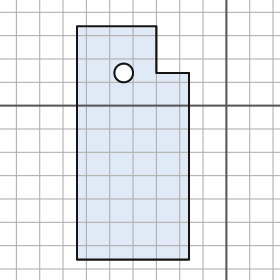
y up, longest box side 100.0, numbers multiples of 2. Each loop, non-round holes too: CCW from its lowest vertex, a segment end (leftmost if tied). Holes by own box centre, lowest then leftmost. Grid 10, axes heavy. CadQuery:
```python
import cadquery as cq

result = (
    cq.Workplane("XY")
    .moveTo(-64.0, -66.0)
    .lineTo(-16.0, -66.0)
    .lineTo(-16.0, 14.0)
    .lineTo(-30.0, 14.0)
    .lineTo(-30.0, 34.0)
    .lineTo(-64.0, 34.0)
    .close()
    .moveTo(-44.0, 14.0)
    .circle(4.0)
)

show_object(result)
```